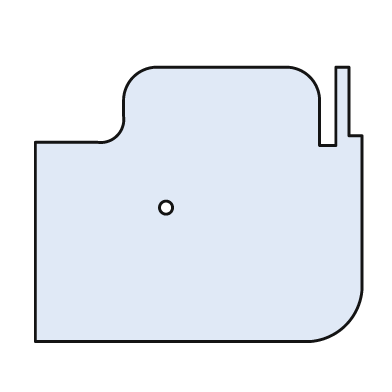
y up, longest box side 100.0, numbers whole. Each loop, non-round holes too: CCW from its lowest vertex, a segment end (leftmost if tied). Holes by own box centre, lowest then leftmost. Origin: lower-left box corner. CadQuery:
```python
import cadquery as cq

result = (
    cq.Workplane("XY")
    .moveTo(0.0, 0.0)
    .lineTo(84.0, 0.0)
    .threePointArc((95.0, 5.0), (100.0, 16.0))
    .lineTo(100.0, 63.0)
    .lineTo(96.0, 63.0)
    .lineTo(96.0, 84.0)
    .lineTo(92.0, 84.0)
    .lineTo(92.0, 60.0)
    .lineTo(87.0, 60.0)
    .lineTo(87.0, 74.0)
    .threePointArc((84.0, 81.0), (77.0, 84.0))
    .lineTo(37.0, 84.0)
    .threePointArc((30.0, 81.0), (27.0, 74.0))
    .lineTo(27.0, 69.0)
    .threePointArc((25.0, 63.0), (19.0, 61.0))
    .lineTo(0.0, 61.0)
    .close()
    .moveTo(40.0, 41.0)
    .circle(2.0)
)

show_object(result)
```